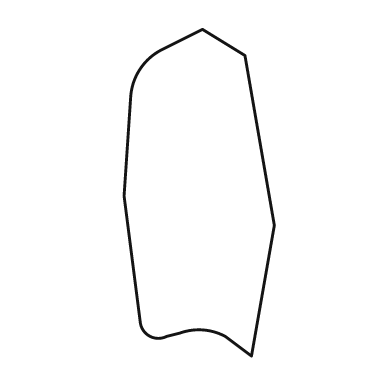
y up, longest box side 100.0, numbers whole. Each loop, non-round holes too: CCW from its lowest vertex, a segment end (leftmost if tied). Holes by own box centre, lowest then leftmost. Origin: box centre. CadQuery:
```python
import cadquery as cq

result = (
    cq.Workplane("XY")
    .moveTo(16.0, -50.0)
    .lineTo(23.0, -10.0)
    .lineTo(14.0, 42.0)
    .lineTo(1.0, 50.0)
    .lineTo(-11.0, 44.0)
    .threePointArc((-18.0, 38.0), (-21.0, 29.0))
    .lineTo(-23.0, -1.0)
    .lineTo(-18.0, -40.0)
    .threePointArc((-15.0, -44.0), (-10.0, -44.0))
    .lineTo(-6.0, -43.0)
    .threePointArc((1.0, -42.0), (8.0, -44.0))
    .close()
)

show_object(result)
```